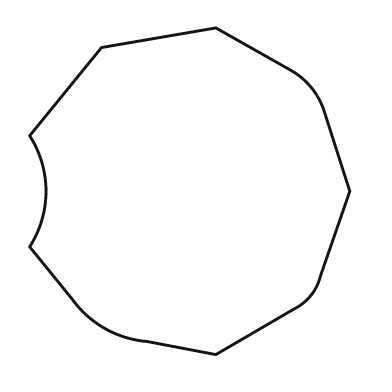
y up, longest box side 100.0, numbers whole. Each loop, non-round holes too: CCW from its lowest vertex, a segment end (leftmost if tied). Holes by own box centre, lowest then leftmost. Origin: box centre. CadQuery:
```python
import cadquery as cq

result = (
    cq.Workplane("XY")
    .moveTo(8.0, -50.0)
    .lineTo(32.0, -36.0)
    .threePointArc((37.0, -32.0), (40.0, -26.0))
    .lineTo(49.0, 0.0)
    .lineTo(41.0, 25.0)
    .threePointArc((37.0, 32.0), (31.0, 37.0))
    .lineTo(8.0, 50.0)
    .lineTo(-27.0, 44.0)
    .lineTo(-49.0, 17.0)
    .threePointArc((-44.0, 0.0), (-49.0, -17.0))
    .lineTo(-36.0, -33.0)
    .threePointArc((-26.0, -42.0), (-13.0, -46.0))
    .close()
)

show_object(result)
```